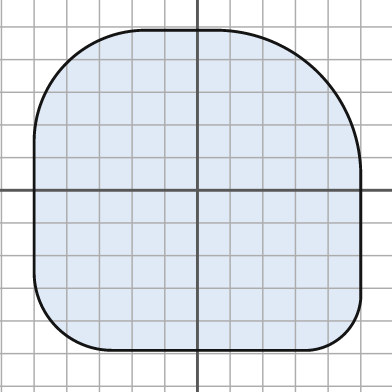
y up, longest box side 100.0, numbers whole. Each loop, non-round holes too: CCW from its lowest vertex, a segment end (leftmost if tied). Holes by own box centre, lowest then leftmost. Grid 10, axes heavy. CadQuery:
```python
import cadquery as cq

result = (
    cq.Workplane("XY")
    .moveTo(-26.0, -49.0)
    .lineTo(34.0, -49.0)
    .threePointArc((45.0, -44.0), (50.0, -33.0))
    .lineTo(50.0, 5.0)
    .threePointArc((37.0, 36.0), (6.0, 49.0))
    .lineTo(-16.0, 49.0)
    .threePointArc((-40.0, 39.0), (-50.0, 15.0))
    .lineTo(-50.0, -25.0)
    .threePointArc((-43.0, -42.0), (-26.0, -49.0))
    .close()
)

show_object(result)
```